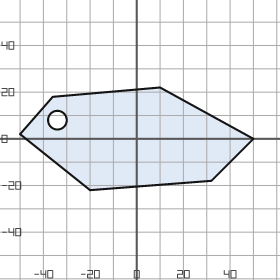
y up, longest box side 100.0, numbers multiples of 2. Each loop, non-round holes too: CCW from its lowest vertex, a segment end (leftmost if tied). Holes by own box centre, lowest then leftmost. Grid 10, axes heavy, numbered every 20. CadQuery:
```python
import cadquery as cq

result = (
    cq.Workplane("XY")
    .moveTo(-20.0, -22.0)
    .lineTo(32.0, -18.0)
    .lineTo(50.0, 0.0)
    .lineTo(10.0, 22.0)
    .lineTo(-36.0, 18.0)
    .lineTo(-50.0, 2.0)
    .close()
    .moveTo(-34.0, 8.0)
    .circle(4.0)
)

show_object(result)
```